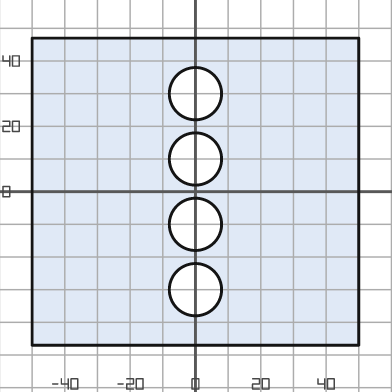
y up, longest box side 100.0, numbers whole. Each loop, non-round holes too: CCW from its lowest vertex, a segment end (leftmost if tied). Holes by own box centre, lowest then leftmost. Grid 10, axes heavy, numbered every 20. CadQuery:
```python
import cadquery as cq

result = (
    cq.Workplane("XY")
    .moveTo(-50.0, -47.0)
    .lineTo(50.0, -47.0)
    .lineTo(50.0, 47.0)
    .lineTo(-50.0, 47.0)
    .close()
    .moveTo(0.0, -30.0)
    .circle(8.0)
    .moveTo(0.0, -10.0)
    .circle(8.0)
    .moveTo(0.0, 10.0)
    .circle(8.0)
    .moveTo(0.0, 30.0)
    .circle(8.0)
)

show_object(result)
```